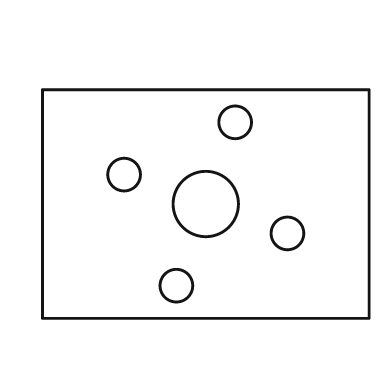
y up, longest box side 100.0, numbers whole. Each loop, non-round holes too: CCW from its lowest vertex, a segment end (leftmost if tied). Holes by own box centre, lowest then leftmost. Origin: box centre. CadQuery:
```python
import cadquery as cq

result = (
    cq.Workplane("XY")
    .moveTo(-50.0, -35.0)
    .lineTo(50.0, -35.0)
    .lineTo(50.0, 35.0)
    .lineTo(-50.0, 35.0)
    .close()
    .moveTo(-9.0, -25.0)
    .circle(5.0)
    .moveTo(25.0, -9.0)
    .circle(5.0)
    .moveTo(0.0, 0.0)
    .circle(10.0)
    .moveTo(-25.0, 9.0)
    .circle(5.0)
    .moveTo(9.0, 25.0)
    .circle(5.0)
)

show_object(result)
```